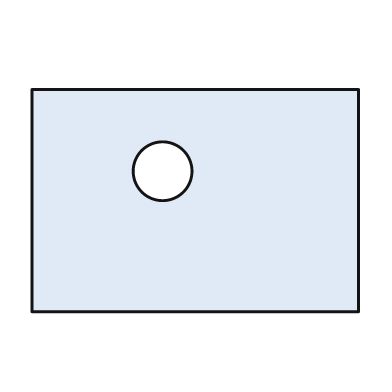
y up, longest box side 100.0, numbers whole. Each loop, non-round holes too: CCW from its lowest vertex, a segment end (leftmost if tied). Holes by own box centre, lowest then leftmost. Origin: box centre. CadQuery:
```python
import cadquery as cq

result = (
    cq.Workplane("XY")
    .moveTo(-50.0, -34.0)
    .lineTo(50.0, -34.0)
    .lineTo(50.0, 34.0)
    .lineTo(-50.0, 34.0)
    .close()
    .moveTo(-10.0, 9.0)
    .circle(9.0)
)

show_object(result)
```